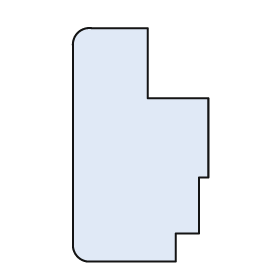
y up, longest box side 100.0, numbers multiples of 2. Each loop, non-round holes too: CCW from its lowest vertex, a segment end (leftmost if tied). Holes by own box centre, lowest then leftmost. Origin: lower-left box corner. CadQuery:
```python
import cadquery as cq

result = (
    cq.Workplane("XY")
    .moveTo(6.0, 0.0)
    .lineTo(44.0, 0.0)
    .lineTo(44.0, 12.0)
    .lineTo(54.0, 12.0)
    .lineTo(54.0, 36.0)
    .lineTo(58.0, 36.0)
    .lineTo(58.0, 70.0)
    .lineTo(32.0, 70.0)
    .lineTo(32.0, 100.0)
    .lineTo(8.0, 100.0)
    .threePointArc((2.0, 98.0), (0.0, 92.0))
    .lineTo(0.0, 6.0)
    .threePointArc((2.0, 2.0), (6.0, 0.0))
    .close()
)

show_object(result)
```